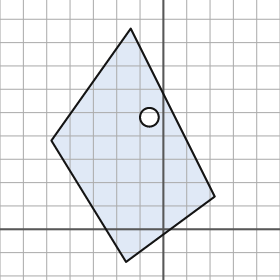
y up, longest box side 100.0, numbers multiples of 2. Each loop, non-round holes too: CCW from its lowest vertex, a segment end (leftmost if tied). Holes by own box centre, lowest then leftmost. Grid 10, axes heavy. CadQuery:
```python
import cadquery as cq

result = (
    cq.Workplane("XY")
    .moveTo(-16.0, -14.0)
    .lineTo(22.0, 14.0)
    .lineTo(-14.0, 86.0)
    .lineTo(-48.0, 38.0)
    .close()
    .moveTo(-6.0, 48.0)
    .circle(4.0)
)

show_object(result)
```